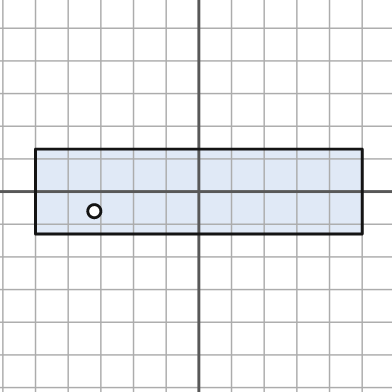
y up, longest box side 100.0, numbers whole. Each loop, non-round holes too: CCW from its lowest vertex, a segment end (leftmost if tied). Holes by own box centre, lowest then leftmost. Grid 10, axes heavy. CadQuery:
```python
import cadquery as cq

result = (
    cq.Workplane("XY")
    .moveTo(-50.0, -13.0)
    .lineTo(50.0, -13.0)
    .lineTo(50.0, 13.0)
    .lineTo(-50.0, 13.0)
    .close()
    .moveTo(-32.0, -6.0)
    .circle(2.0)
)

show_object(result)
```